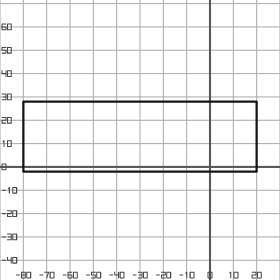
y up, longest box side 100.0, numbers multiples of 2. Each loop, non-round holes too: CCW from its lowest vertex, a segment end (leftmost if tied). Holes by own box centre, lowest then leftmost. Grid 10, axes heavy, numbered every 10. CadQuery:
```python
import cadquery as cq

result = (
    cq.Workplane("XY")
    .moveTo(-80.0, -2.0)
    .lineTo(20.0, -2.0)
    .lineTo(20.0, 28.0)
    .lineTo(-80.0, 28.0)
    .close()
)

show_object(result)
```